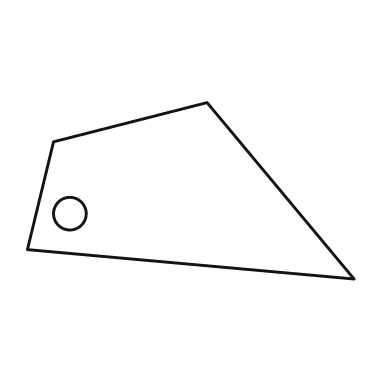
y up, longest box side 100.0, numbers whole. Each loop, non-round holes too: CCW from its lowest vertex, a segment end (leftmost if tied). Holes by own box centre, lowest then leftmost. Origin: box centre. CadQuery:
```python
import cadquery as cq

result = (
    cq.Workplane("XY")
    .moveTo(50.0, -27.0)
    .lineTo(5.0, 27.0)
    .lineTo(-42.0, 15.0)
    .lineTo(-50.0, -18.0)
    .close()
    .moveTo(-37.0, -7.0)
    .circle(5.0)
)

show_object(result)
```